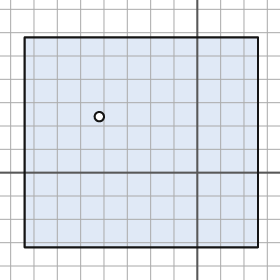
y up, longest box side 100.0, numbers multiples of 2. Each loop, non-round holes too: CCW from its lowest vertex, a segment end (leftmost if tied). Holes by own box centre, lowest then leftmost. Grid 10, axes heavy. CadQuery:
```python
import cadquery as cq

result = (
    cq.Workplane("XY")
    .moveTo(-74.0, -32.0)
    .lineTo(26.0, -32.0)
    .lineTo(26.0, 58.0)
    .lineTo(-74.0, 58.0)
    .close()
    .moveTo(-42.0, 24.0)
    .circle(2.0)
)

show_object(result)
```